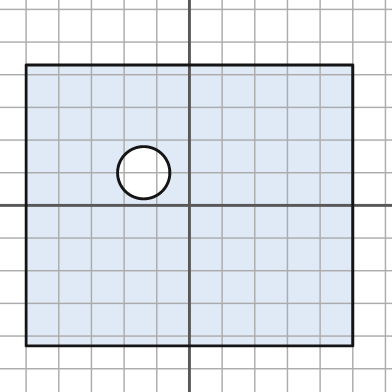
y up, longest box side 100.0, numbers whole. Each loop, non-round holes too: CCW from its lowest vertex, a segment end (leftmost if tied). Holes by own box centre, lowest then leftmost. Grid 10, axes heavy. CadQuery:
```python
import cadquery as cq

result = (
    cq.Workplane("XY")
    .moveTo(-50.0, -43.0)
    .lineTo(50.0, -43.0)
    .lineTo(50.0, 43.0)
    .lineTo(-50.0, 43.0)
    .close()
    .moveTo(-14.0, 10.0)
    .circle(8.0)
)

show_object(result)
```